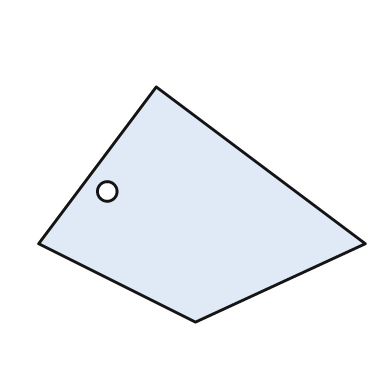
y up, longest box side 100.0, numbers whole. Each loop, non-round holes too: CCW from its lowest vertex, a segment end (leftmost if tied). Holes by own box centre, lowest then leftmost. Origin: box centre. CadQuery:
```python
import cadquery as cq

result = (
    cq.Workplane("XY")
    .moveTo(-2.0, -36.0)
    .lineTo(50.0, -12.0)
    .lineTo(-14.0, 36.0)
    .lineTo(-50.0, -12.0)
    .close()
    .moveTo(-29.0, 4.0)
    .circle(3.0)
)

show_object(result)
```